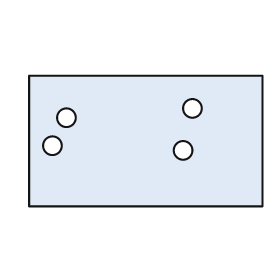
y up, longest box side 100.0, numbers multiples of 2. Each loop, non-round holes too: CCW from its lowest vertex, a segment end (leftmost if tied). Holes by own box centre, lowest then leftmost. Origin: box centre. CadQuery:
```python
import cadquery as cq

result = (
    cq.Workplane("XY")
    .moveTo(-50.0, -28.0)
    .lineTo(50.0, -28.0)
    .lineTo(50.0, 28.0)
    .lineTo(-50.0, 28.0)
    .close()
    .moveTo(16.0, -4.0)
    .circle(4.0)
    .moveTo(-40.0, -2.0)
    .circle(4.0)
    .moveTo(-34.0, 10.0)
    .circle(4.0)
    .moveTo(20.0, 14.0)
    .circle(4.0)
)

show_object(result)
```